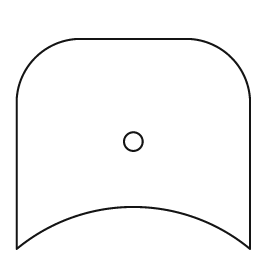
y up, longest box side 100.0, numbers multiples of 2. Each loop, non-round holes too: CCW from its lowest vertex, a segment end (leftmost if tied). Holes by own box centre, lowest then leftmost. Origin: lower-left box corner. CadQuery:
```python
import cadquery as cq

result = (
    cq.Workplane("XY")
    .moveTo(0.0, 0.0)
    .threePointArc((50.0, 18.0), (100.0, 0.0))
    .lineTo(100.0, 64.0)
    .threePointArc((92.0, 82.0), (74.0, 90.0))
    .lineTo(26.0, 90.0)
    .threePointArc((8.0, 82.0), (0.0, 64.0))
    .close()
    .moveTo(50.0, 46.0)
    .circle(4.0)
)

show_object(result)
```